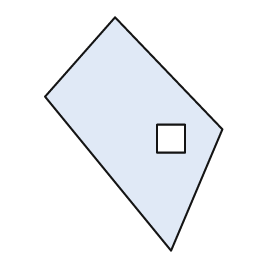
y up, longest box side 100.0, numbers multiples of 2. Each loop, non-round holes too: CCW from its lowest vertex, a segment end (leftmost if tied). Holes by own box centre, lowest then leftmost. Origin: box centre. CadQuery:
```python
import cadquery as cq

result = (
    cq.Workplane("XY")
    .moveTo(16.0, -50.0)
    .lineTo(38.0, 2.0)
    .lineTo(-8.0, 50.0)
    .lineTo(-38.0, 16.0)
    .close()
    .moveTo(10.0, -8.0)
    .lineTo(22.0, -8.0)
    .lineTo(22.0, 4.0)
    .lineTo(10.0, 4.0)
    .close()
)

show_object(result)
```